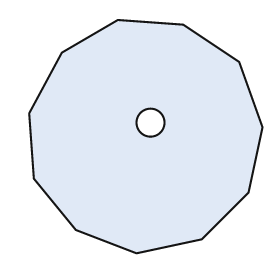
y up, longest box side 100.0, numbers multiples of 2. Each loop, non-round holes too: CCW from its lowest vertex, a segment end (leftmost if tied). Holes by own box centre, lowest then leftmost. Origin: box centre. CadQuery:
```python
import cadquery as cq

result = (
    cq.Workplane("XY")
    .moveTo(-4.0, -50.0)
    .lineTo(24.0, -44.0)
    .lineTo(44.0, -24.0)
    .lineTo(50.0, 4.0)
    .lineTo(40.0, 32.0)
    .lineTo(16.0, 48.0)
    .lineTo(-12.0, 50.0)
    .lineTo(-36.0, 36.0)
    .lineTo(-50.0, 10.0)
    .lineTo(-48.0, -18.0)
    .lineTo(-30.0, -40.0)
    .close()
    .moveTo(2.0, 6.0)
    .circle(6.0)
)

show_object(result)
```